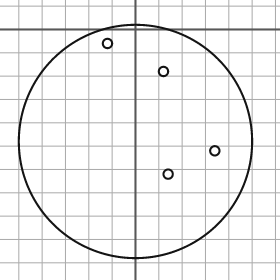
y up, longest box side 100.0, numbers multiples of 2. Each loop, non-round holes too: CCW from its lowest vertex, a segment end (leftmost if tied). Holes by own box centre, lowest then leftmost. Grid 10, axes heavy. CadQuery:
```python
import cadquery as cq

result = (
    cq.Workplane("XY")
    .moveTo(0.0, -48.0)
    .circle(50.0)
    .moveTo(14.0, -62.0)
    .circle(2.0)
    .moveTo(34.0, -52.0)
    .circle(2.0)
    .moveTo(12.0, -18.0)
    .circle(2.0)
    .moveTo(-12.0, -6.0)
    .circle(2.0)
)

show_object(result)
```